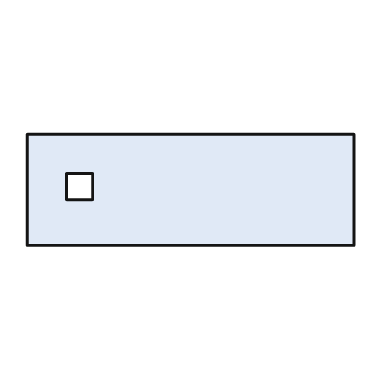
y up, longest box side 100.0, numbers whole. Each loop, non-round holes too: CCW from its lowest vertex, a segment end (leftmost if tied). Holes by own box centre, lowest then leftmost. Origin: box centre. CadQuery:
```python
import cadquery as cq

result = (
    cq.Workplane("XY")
    .moveTo(-50.0, -17.0)
    .lineTo(50.0, -17.0)
    .lineTo(50.0, 17.0)
    .lineTo(-50.0, 17.0)
    .close()
    .moveTo(-38.0, -3.0)
    .lineTo(-30.0, -3.0)
    .lineTo(-30.0, 5.0)
    .lineTo(-38.0, 5.0)
    .close()
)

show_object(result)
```